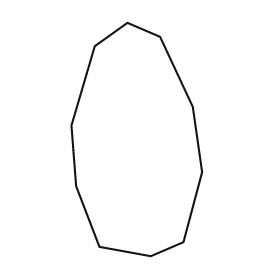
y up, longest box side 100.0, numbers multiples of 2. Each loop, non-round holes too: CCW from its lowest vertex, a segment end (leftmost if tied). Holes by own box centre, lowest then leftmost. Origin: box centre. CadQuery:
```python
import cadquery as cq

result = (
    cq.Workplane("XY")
    .moveTo(6.0, -50.0)
    .lineTo(20.0, -44.0)
    .lineTo(28.0, -14.0)
    .lineTo(24.0, 14.0)
    .lineTo(10.0, 44.0)
    .lineTo(-4.0, 50.0)
    .lineTo(-18.0, 40.0)
    .lineTo(-28.0, 6.0)
    .lineTo(-26.0, -20.0)
    .lineTo(-16.0, -46.0)
    .close()
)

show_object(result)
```